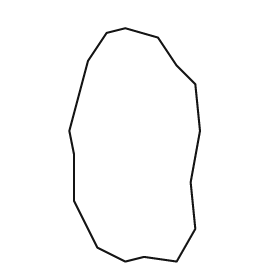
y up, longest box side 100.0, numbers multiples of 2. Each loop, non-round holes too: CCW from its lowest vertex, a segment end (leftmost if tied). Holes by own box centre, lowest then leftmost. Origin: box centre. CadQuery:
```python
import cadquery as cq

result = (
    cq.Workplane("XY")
    .moveTo(-4.0, -50.0)
    .lineTo(4.0, -48.0)
    .lineTo(18.0, -50.0)
    .lineTo(26.0, -36.0)
    .lineTo(24.0, -16.0)
    .lineTo(28.0, 6.0)
    .lineTo(26.0, 26.0)
    .lineTo(18.0, 34.0)
    .lineTo(10.0, 46.0)
    .lineTo(-4.0, 50.0)
    .lineTo(-12.0, 48.0)
    .lineTo(-20.0, 36.0)
    .lineTo(-28.0, 6.0)
    .lineTo(-26.0, -4.0)
    .lineTo(-26.0, -24.0)
    .lineTo(-16.0, -44.0)
    .close()
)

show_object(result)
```